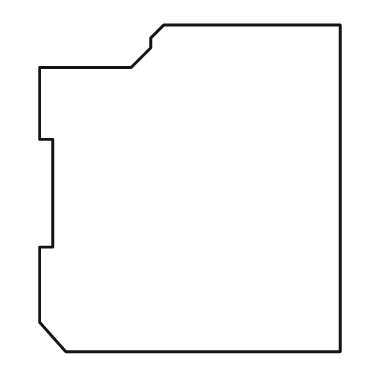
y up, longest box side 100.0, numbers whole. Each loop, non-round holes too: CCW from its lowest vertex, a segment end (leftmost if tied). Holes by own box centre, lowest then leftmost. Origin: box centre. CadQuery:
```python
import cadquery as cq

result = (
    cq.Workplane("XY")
    .moveTo(-38.0, -50.0)
    .lineTo(46.0, -50.0)
    .lineTo(46.0, 50.0)
    .lineTo(-8.0, 50.0)
    .lineTo(-12.0, 46.0)
    .lineTo(-12.0, 43.0)
    .lineTo(-18.0, 37.0)
    .lineTo(-46.0, 37.0)
    .lineTo(-46.0, 15.0)
    .lineTo(-42.0, 15.0)
    .lineTo(-42.0, -18.0)
    .lineTo(-46.0, -18.0)
    .lineTo(-46.0, -41.0)
    .close()
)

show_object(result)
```